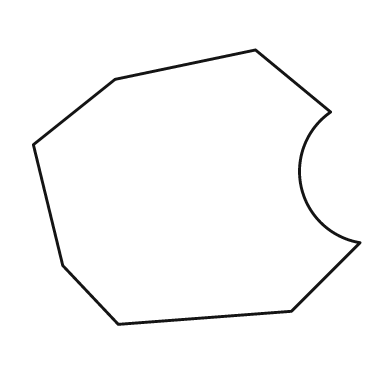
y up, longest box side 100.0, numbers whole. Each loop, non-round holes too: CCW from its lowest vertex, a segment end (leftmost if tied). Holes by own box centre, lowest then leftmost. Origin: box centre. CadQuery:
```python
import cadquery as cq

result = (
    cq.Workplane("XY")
    .moveTo(-24.0, -42.0)
    .lineTo(29.0, -38.0)
    .lineTo(50.0, -17.0)
    .threePointArc((32.0, 0.0), (41.0, 23.0))
    .lineTo(18.0, 42.0)
    .lineTo(-25.0, 33.0)
    .lineTo(-50.0, 13.0)
    .lineTo(-41.0, -24.0)
    .close()
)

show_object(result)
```